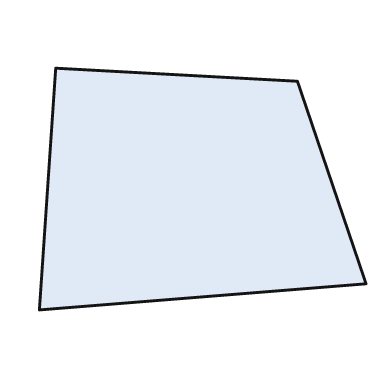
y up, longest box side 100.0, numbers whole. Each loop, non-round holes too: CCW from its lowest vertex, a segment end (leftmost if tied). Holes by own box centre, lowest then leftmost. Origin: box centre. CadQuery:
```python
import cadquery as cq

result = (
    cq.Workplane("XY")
    .moveTo(-50.0, -37.0)
    .lineTo(50.0, -29.0)
    .lineTo(29.0, 33.0)
    .lineTo(-45.0, 37.0)
    .close()
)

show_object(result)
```